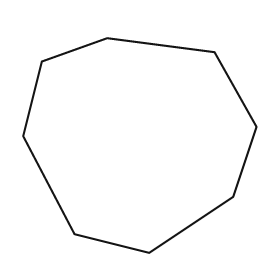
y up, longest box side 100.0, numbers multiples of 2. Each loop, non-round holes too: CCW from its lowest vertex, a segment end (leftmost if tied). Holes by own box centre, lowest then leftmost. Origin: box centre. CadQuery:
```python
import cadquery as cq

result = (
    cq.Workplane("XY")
    .moveTo(4.0, -46.0)
    .lineTo(40.0, -22.0)
    .lineTo(50.0, 8.0)
    .lineTo(32.0, 40.0)
    .lineTo(-14.0, 46.0)
    .lineTo(-42.0, 36.0)
    .lineTo(-50.0, 4.0)
    .lineTo(-28.0, -38.0)
    .close()
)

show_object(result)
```